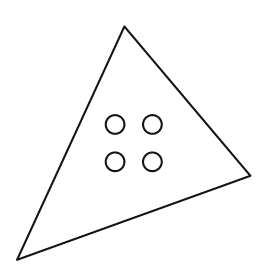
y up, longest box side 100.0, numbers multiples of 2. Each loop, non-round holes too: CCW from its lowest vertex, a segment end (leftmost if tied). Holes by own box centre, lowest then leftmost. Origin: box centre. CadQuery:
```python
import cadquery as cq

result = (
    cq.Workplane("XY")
    .moveTo(-50.0, -50.0)
    .lineTo(50.0, -14.0)
    .lineTo(-4.0, 50.0)
    .close()
    .moveTo(-8.0, -8.0)
    .circle(4.0)
    .moveTo(8.0, -8.0)
    .circle(4.0)
    .moveTo(-8.0, 8.0)
    .circle(4.0)
    .moveTo(8.0, 8.0)
    .circle(4.0)
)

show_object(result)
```